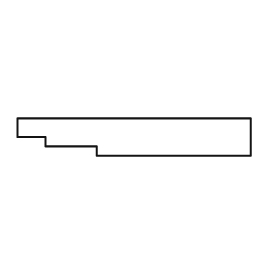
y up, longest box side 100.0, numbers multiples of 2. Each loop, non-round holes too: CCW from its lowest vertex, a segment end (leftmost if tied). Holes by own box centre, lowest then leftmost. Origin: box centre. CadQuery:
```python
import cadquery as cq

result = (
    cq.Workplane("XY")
    .moveTo(-16.0, -8.0)
    .lineTo(50.0, -8.0)
    .lineTo(50.0, 8.0)
    .lineTo(-50.0, 8.0)
    .lineTo(-50.0, 0.0)
    .lineTo(-38.0, 0.0)
    .lineTo(-38.0, -4.0)
    .lineTo(-16.0, -4.0)
    .close()
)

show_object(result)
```